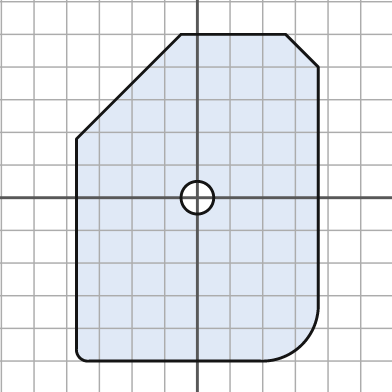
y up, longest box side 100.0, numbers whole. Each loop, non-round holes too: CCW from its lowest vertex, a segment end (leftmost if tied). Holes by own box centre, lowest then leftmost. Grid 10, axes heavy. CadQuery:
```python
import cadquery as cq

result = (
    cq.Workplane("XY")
    .moveTo(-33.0, -50.0)
    .lineTo(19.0, -50.0)
    .threePointArc((32.0, -45.0), (37.0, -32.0))
    .lineTo(37.0, 40.0)
    .lineTo(27.0, 50.0)
    .lineTo(-5.0, 50.0)
    .lineTo(-37.0, 18.0)
    .lineTo(-37.0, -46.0)
    .threePointArc((-36.0, -49.0), (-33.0, -50.0))
    .close()
    .moveTo(0.0, 0.0)
    .circle(5.0)
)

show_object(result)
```